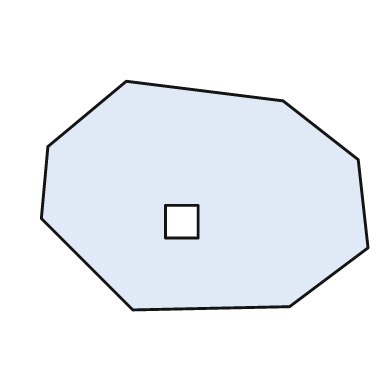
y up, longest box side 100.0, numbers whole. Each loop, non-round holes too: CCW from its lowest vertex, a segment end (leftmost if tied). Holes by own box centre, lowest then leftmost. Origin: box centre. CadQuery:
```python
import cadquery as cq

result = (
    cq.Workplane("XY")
    .moveTo(-22.0, -35.0)
    .lineTo(26.0, -34.0)
    .lineTo(50.0, -16.0)
    .lineTo(47.0, 11.0)
    .lineTo(24.0, 29.0)
    .lineTo(-24.0, 35.0)
    .lineTo(-48.0, 15.0)
    .lineTo(-50.0, -7.0)
    .close()
    .moveTo(-12.0, -13.0)
    .lineTo(-2.0, -13.0)
    .lineTo(-2.0, -3.0)
    .lineTo(-12.0, -3.0)
    .close()
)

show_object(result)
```